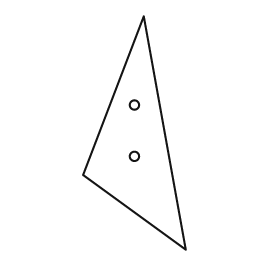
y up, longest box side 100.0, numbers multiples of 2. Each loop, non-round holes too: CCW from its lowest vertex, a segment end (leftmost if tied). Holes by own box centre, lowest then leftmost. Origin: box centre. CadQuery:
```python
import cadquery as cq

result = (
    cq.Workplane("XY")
    .moveTo(22.0, -50.0)
    .lineTo(4.0, 50.0)
    .lineTo(-22.0, -18.0)
    .close()
    .moveTo(0.0, -10.0)
    .circle(2.0)
    .moveTo(0.0, 12.0)
    .circle(2.0)
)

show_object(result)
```